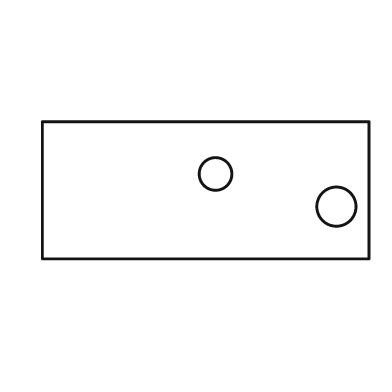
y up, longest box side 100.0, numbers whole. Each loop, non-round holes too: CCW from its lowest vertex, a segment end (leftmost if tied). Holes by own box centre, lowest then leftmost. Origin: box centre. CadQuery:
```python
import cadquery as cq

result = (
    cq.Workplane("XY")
    .moveTo(-50.0, -21.0)
    .lineTo(50.0, -21.0)
    .lineTo(50.0, 21.0)
    .lineTo(-50.0, 21.0)
    .close()
    .moveTo(40.0, -5.0)
    .circle(6.0)
    .moveTo(3.0, 5.0)
    .circle(5.0)
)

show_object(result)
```